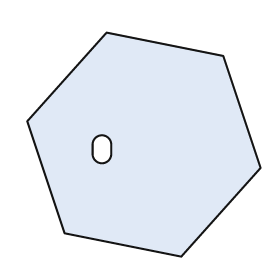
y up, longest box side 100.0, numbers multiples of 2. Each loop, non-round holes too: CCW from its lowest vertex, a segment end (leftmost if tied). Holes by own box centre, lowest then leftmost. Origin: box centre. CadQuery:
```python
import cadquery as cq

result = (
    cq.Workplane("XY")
    .moveTo(16.0, -48.0)
    .lineTo(50.0, -10.0)
    .lineTo(34.0, 38.0)
    .lineTo(-16.0, 48.0)
    .lineTo(-50.0, 10.0)
    .lineTo(-34.0, -38.0)
    .close()
    .moveTo(-22.0, -4.0)
    .threePointArc((-18.0, -8.0), (-14.0, -4.0))
    .lineTo(-14.0, 0.0)
    .threePointArc((-18.0, 4.0), (-22.0, 0.0))
    .close()
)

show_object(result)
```